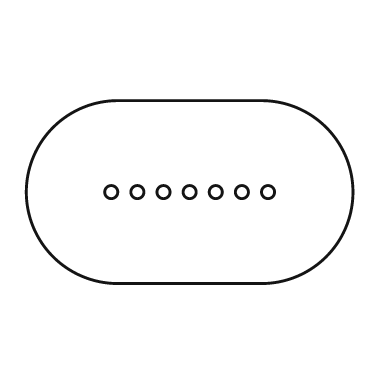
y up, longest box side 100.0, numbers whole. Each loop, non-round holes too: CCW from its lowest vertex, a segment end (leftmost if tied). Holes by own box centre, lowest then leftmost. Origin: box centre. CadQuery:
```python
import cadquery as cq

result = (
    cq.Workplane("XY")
    .moveTo(-22.0, -28.0)
    .lineTo(22.0, -28.0)
    .threePointArc((50.0, 0.0), (22.0, 28.0))
    .lineTo(-22.0, 28.0)
    .threePointArc((-50.0, 0.0), (-22.0, -28.0))
    .close()
    .moveTo(-24.0, 0.0)
    .circle(2.0)
    .moveTo(-16.0, 0.0)
    .circle(2.0)
    .moveTo(-8.0, 0.0)
    .circle(2.0)
    .moveTo(0.0, 0.0)
    .circle(2.0)
    .moveTo(8.0, 0.0)
    .circle(2.0)
    .moveTo(16.0, 0.0)
    .circle(2.0)
    .moveTo(24.0, 0.0)
    .circle(2.0)
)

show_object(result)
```